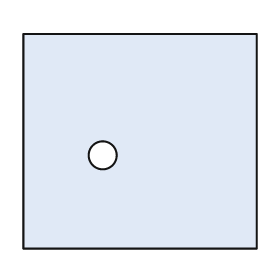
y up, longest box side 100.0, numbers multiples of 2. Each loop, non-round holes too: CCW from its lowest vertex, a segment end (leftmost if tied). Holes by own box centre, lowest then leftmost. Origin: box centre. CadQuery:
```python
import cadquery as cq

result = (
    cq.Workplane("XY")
    .moveTo(-50.0, -46.0)
    .lineTo(50.0, -46.0)
    .lineTo(50.0, 46.0)
    .lineTo(-50.0, 46.0)
    .close()
    .moveTo(-16.0, -6.0)
    .circle(6.0)
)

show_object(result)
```